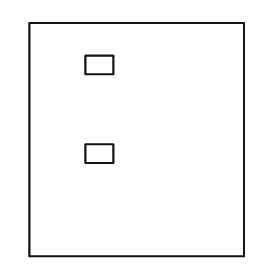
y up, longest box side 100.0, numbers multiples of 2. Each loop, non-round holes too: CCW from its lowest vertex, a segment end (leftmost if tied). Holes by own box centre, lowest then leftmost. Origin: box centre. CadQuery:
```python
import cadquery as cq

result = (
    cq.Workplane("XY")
    .moveTo(-46.0, -50.0)
    .lineTo(46.0, -50.0)
    .lineTo(46.0, 50.0)
    .lineTo(-46.0, 50.0)
    .close()
    .moveTo(-22.0, -10.0)
    .lineTo(-10.0, -10.0)
    .lineTo(-10.0, -2.0)
    .lineTo(-22.0, -2.0)
    .close()
    .moveTo(-22.0, 28.0)
    .lineTo(-10.0, 28.0)
    .lineTo(-10.0, 36.0)
    .lineTo(-22.0, 36.0)
    .close()
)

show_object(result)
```